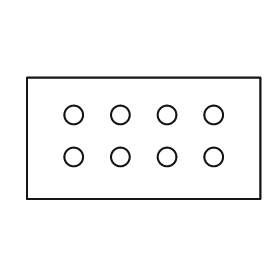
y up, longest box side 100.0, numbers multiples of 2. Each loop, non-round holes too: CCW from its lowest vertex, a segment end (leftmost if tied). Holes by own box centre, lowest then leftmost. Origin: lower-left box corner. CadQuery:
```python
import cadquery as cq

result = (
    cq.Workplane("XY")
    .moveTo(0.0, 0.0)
    .lineTo(100.0, 0.0)
    .lineTo(100.0, 52.0)
    .lineTo(0.0, 52.0)
    .close()
    .moveTo(20.0, 18.0)
    .circle(4.0)
    .moveTo(40.0, 18.0)
    .circle(4.0)
    .moveTo(60.0, 18.0)
    .circle(4.0)
    .moveTo(80.0, 18.0)
    .circle(4.0)
    .moveTo(20.0, 36.0)
    .circle(4.0)
    .moveTo(40.0, 36.0)
    .circle(4.0)
    .moveTo(60.0, 36.0)
    .circle(4.0)
    .moveTo(80.0, 36.0)
    .circle(4.0)
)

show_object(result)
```